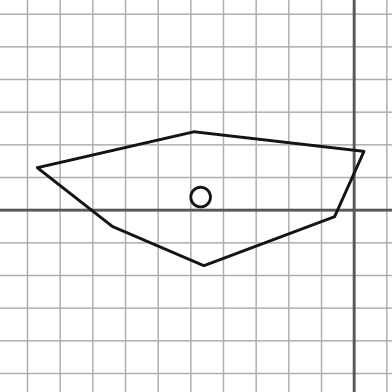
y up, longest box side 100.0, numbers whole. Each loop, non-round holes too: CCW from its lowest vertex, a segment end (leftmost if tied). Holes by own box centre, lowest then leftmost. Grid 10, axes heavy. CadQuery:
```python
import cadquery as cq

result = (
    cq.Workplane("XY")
    .moveTo(-46.0, -17.0)
    .lineTo(-6.0, -2.0)
    .lineTo(3.0, 18.0)
    .lineTo(-49.0, 24.0)
    .lineTo(-97.0, 13.0)
    .lineTo(-74.0, -5.0)
    .close()
    .moveTo(-47.0, 4.0)
    .circle(3.0)
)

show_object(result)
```